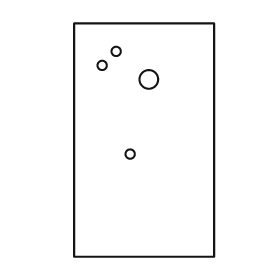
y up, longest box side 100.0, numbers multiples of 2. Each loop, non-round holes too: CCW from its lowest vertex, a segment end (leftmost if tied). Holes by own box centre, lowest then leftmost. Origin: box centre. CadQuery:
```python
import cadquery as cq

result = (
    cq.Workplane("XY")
    .moveTo(-30.0, -50.0)
    .lineTo(30.0, -50.0)
    .lineTo(30.0, 50.0)
    .lineTo(-30.0, 50.0)
    .close()
    .moveTo(-6.0, -6.0)
    .circle(2.0)
    .moveTo(2.0, 26.0)
    .circle(4.0)
    .moveTo(-18.0, 32.0)
    .circle(2.0)
    .moveTo(-12.0, 38.0)
    .circle(2.0)
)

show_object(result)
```